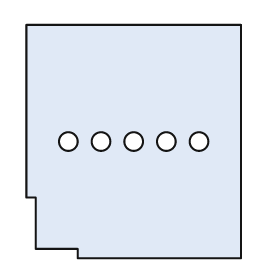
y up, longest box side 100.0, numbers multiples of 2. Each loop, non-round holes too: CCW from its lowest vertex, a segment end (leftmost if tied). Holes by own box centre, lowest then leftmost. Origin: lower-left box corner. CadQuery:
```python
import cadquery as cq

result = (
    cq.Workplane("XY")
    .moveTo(22.0, 0.0)
    .lineTo(92.0, 0.0)
    .lineTo(92.0, 100.0)
    .lineTo(0.0, 100.0)
    .lineTo(0.0, 26.0)
    .lineTo(4.0, 26.0)
    .lineTo(4.0, 4.0)
    .lineTo(22.0, 4.0)
    .close()
    .moveTo(18.0, 50.0)
    .circle(4.0)
    .moveTo(32.0, 50.0)
    .circle(4.0)
    .moveTo(46.0, 50.0)
    .circle(4.0)
    .moveTo(60.0, 50.0)
    .circle(4.0)
    .moveTo(74.0, 50.0)
    .circle(4.0)
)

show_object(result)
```